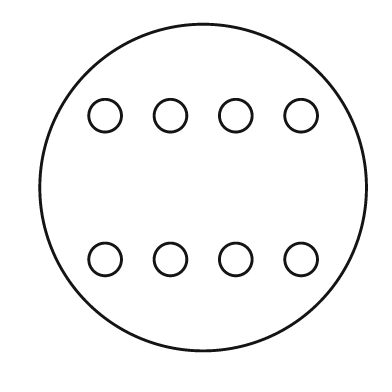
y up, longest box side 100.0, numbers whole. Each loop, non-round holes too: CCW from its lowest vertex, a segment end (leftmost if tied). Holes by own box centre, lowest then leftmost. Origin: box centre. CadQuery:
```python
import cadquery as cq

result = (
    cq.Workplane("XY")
    .moveTo(0.0, 0.0)
    .circle(50.0)
    .moveTo(-30.0, -22.0)
    .circle(5.0)
    .moveTo(-10.0, -22.0)
    .circle(5.0)
    .moveTo(10.0, -22.0)
    .circle(5.0)
    .moveTo(30.0, -22.0)
    .circle(5.0)
    .moveTo(-30.0, 22.0)
    .circle(5.0)
    .moveTo(-10.0, 22.0)
    .circle(5.0)
    .moveTo(10.0, 22.0)
    .circle(5.0)
    .moveTo(30.0, 22.0)
    .circle(5.0)
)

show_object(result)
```